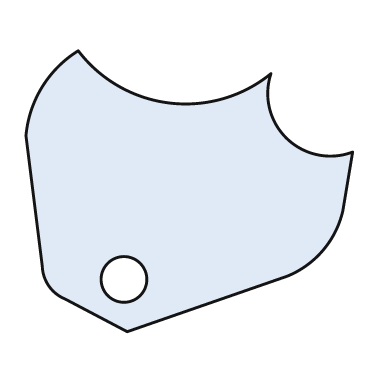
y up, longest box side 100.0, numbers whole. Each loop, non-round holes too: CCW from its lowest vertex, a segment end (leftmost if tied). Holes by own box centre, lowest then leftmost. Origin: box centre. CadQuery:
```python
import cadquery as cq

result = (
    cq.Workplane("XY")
    .moveTo(-19.0, -43.0)
    .lineTo(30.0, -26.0)
    .threePointArc((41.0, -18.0), (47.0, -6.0))
    .lineTo(50.0, 12.0)
    .threePointArc((30.0, 16.0), (25.0, 36.0))
    .threePointArc((-6.0, 27.0), (-34.0, 43.0))
    .threePointArc((-45.0, 32.0), (-50.0, 17.0))
    .lineTo(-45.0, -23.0)
    .threePointArc((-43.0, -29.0), (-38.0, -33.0))
    .close()
    .moveTo(-20.0, -27.0)
    .circle(7.0)
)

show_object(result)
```